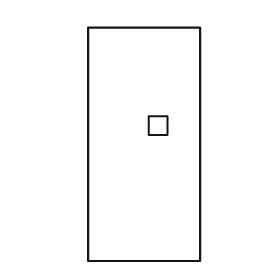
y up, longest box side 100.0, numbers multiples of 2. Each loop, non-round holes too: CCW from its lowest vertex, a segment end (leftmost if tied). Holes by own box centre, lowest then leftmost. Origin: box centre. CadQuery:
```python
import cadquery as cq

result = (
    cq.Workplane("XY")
    .moveTo(-24.0, -50.0)
    .lineTo(24.0, -50.0)
    .lineTo(24.0, 50.0)
    .lineTo(-24.0, 50.0)
    .close()
    .moveTo(2.0, 4.0)
    .lineTo(10.0, 4.0)
    .lineTo(10.0, 12.0)
    .lineTo(2.0, 12.0)
    .close()
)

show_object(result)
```